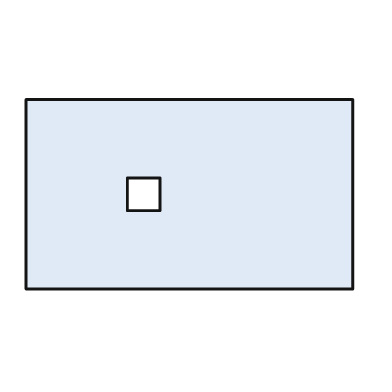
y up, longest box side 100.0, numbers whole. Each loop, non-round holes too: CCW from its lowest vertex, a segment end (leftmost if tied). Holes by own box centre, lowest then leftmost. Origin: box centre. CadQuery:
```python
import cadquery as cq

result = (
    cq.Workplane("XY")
    .moveTo(-50.0, -29.0)
    .lineTo(50.0, -29.0)
    .lineTo(50.0, 29.0)
    .lineTo(-50.0, 29.0)
    .close()
    .moveTo(-19.0, -5.0)
    .lineTo(-9.0, -5.0)
    .lineTo(-9.0, 5.0)
    .lineTo(-19.0, 5.0)
    .close()
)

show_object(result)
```